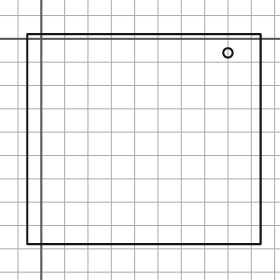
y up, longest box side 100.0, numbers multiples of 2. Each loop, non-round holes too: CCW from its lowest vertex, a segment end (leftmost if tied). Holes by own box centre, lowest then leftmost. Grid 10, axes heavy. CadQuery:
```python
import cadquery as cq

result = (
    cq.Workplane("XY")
    .moveTo(-6.0, -88.0)
    .lineTo(94.0, -88.0)
    .lineTo(94.0, 2.0)
    .lineTo(-6.0, 2.0)
    .close()
    .moveTo(80.0, -6.0)
    .circle(2.0)
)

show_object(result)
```